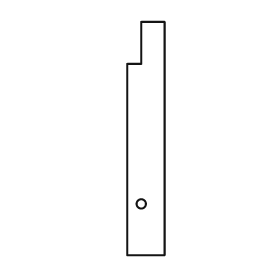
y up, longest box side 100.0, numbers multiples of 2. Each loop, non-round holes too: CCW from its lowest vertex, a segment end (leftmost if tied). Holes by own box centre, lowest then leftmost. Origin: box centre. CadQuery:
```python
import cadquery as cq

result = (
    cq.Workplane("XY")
    .moveTo(-8.0, -50.0)
    .lineTo(8.0, -50.0)
    .lineTo(8.0, 50.0)
    .lineTo(-2.0, 50.0)
    .lineTo(-2.0, 32.0)
    .lineTo(-8.0, 32.0)
    .close()
    .moveTo(-2.0, -28.0)
    .circle(2.0)
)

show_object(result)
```